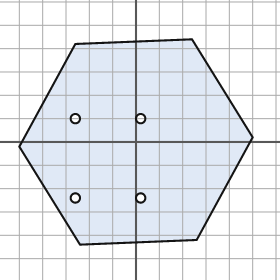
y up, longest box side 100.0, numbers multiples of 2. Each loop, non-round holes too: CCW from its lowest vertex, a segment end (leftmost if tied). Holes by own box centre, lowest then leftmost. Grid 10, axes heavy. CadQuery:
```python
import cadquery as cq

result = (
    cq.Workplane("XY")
    .moveTo(-24.0, -44.0)
    .lineTo(26.0, -42.0)
    .lineTo(50.0, 2.0)
    .lineTo(24.0, 44.0)
    .lineTo(-26.0, 42.0)
    .lineTo(-50.0, -2.0)
    .close()
    .moveTo(-26.0, -24.0)
    .circle(2.0)
    .moveTo(2.0, -24.0)
    .circle(2.0)
    .moveTo(-26.0, 10.0)
    .circle(2.0)
    .moveTo(2.0, 10.0)
    .circle(2.0)
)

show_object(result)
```